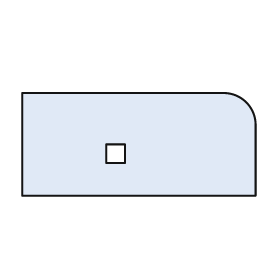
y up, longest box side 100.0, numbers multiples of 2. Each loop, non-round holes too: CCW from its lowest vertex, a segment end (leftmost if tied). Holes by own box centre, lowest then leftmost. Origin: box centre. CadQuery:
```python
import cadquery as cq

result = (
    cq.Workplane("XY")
    .moveTo(-50.0, -22.0)
    .lineTo(50.0, -22.0)
    .lineTo(50.0, 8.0)
    .threePointArc((46.0, 18.0), (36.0, 22.0))
    .lineTo(-50.0, 22.0)
    .close()
    .moveTo(-14.0, -8.0)
    .lineTo(-6.0, -8.0)
    .lineTo(-6.0, 0.0)
    .lineTo(-14.0, 0.0)
    .close()
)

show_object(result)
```